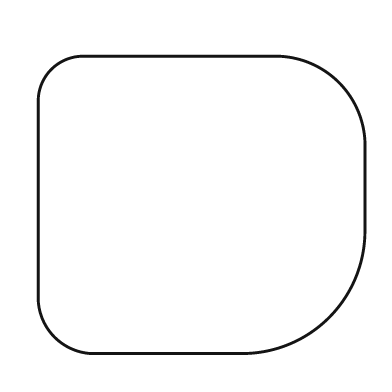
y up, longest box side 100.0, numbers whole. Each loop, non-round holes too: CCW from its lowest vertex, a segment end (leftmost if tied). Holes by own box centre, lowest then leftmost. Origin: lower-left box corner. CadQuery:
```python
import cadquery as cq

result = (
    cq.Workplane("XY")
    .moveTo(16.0, 0.0)
    .lineTo(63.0, 0.0)
    .threePointArc((89.0, 11.0), (100.0, 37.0))
    .lineTo(100.0, 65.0)
    .threePointArc((92.0, 83.0), (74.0, 91.0))
    .lineTo(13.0, 91.0)
    .threePointArc((4.0, 87.0), (0.0, 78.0))
    .lineTo(0.0, 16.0)
    .threePointArc((5.0, 5.0), (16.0, 0.0))
    .close()
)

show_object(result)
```